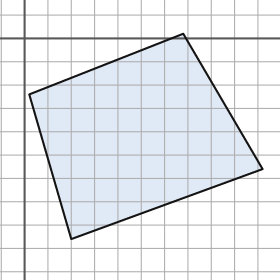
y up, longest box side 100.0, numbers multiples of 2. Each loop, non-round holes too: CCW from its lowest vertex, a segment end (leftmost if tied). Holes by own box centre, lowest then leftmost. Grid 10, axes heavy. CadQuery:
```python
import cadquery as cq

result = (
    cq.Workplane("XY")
    .moveTo(20.0, -86.0)
    .lineTo(102.0, -56.0)
    .lineTo(68.0, 2.0)
    .lineTo(2.0, -24.0)
    .close()
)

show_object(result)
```